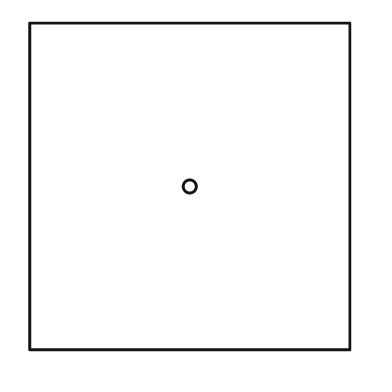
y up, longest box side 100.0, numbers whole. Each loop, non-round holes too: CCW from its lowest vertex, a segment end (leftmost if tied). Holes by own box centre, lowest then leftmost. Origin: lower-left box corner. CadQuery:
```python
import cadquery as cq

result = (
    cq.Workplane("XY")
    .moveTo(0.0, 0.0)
    .lineTo(98.0, 0.0)
    .lineTo(98.0, 100.0)
    .lineTo(0.0, 100.0)
    .close()
    .moveTo(49.0, 50.0)
    .circle(2.0)
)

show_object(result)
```